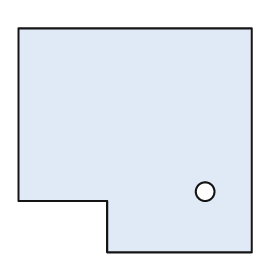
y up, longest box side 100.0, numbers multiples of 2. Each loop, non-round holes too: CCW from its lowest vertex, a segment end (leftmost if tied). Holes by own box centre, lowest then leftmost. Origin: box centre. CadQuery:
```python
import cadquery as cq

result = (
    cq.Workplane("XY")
    .moveTo(-12.0, -48.0)
    .lineTo(50.0, -48.0)
    .lineTo(50.0, 48.0)
    .lineTo(-50.0, 48.0)
    .lineTo(-50.0, -26.0)
    .lineTo(-12.0, -26.0)
    .close()
    .moveTo(30.0, -22.0)
    .circle(4.0)
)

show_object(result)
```